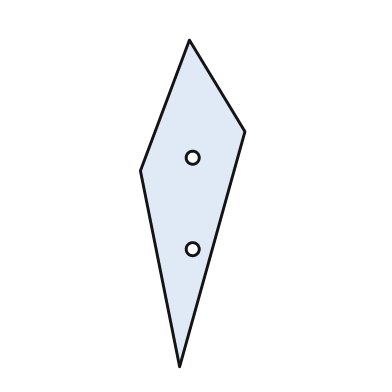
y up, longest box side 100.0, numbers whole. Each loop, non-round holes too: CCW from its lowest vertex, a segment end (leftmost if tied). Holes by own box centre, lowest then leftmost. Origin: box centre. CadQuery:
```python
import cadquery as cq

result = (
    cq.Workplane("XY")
    .moveTo(-4.0, -50.0)
    .lineTo(16.0, 22.0)
    .lineTo(-1.0, 50.0)
    .lineTo(-16.0, 10.0)
    .close()
    .moveTo(0.0, -14.0)
    .circle(2.0)
    .moveTo(0.0, 14.0)
    .circle(2.0)
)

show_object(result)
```